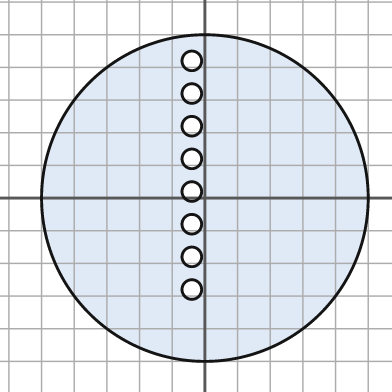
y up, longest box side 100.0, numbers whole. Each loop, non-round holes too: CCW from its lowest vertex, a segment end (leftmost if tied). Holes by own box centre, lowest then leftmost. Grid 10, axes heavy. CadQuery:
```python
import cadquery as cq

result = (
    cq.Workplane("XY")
    .moveTo(0.0, 0.0)
    .circle(50.0)
    .moveTo(-4.0, -28.0)
    .circle(3.0)
    .moveTo(-4.0, -18.0)
    .circle(3.0)
    .moveTo(-4.0, -8.0)
    .circle(3.0)
    .moveTo(-4.0, 2.0)
    .circle(3.0)
    .moveTo(-4.0, 12.0)
    .circle(3.0)
    .moveTo(-4.0, 22.0)
    .circle(3.0)
    .moveTo(-4.0, 32.0)
    .circle(3.0)
    .moveTo(-4.0, 42.0)
    .circle(3.0)
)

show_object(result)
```